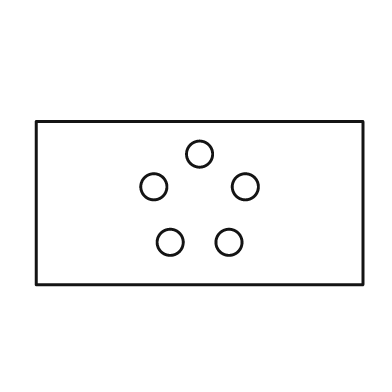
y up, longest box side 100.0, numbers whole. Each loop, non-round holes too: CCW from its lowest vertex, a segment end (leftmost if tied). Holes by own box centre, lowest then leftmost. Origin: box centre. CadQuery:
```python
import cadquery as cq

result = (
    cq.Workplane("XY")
    .moveTo(-50.0, -25.0)
    .lineTo(50.0, -25.0)
    .lineTo(50.0, 25.0)
    .lineTo(-50.0, 25.0)
    .close()
    .moveTo(-9.0, -12.0)
    .circle(4.0)
    .moveTo(9.0, -12.0)
    .circle(4.0)
    .moveTo(-14.0, 5.0)
    .circle(4.0)
    .moveTo(14.0, 5.0)
    .circle(4.0)
    .moveTo(0.0, 15.0)
    .circle(4.0)
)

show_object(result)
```